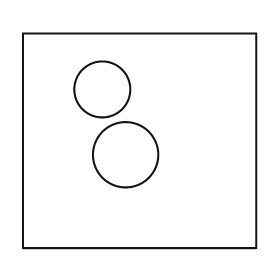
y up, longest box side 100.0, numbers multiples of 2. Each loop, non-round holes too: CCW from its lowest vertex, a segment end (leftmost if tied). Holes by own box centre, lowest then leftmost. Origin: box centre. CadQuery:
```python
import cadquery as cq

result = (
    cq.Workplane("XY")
    .moveTo(-50.0, -46.0)
    .lineTo(50.0, -46.0)
    .lineTo(50.0, 46.0)
    .lineTo(-50.0, 46.0)
    .close()
    .moveTo(-6.0, -6.0)
    .circle(14.0)
    .moveTo(-16.0, 22.0)
    .circle(12.0)
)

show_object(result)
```